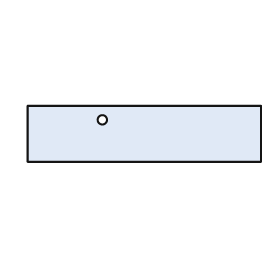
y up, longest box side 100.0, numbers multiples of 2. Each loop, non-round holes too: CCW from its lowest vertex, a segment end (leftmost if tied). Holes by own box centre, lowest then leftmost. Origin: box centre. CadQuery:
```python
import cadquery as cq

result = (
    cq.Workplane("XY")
    .moveTo(-50.0, -12.0)
    .lineTo(50.0, -12.0)
    .lineTo(50.0, 12.0)
    .lineTo(-50.0, 12.0)
    .close()
    .moveTo(-18.0, 6.0)
    .circle(2.0)
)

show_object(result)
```